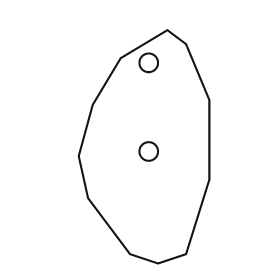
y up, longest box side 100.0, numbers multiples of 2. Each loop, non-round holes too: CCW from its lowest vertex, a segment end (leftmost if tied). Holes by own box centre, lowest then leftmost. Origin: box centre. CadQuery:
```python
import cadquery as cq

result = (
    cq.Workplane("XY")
    .moveTo(6.0, -50.0)
    .lineTo(18.0, -46.0)
    .lineTo(28.0, -14.0)
    .lineTo(28.0, 20.0)
    .lineTo(18.0, 44.0)
    .lineTo(10.0, 50.0)
    .lineTo(-10.0, 38.0)
    .lineTo(-22.0, 18.0)
    .lineTo(-28.0, -4.0)
    .lineTo(-24.0, -22.0)
    .lineTo(-6.0, -46.0)
    .close()
    .moveTo(2.0, -2.0)
    .circle(4.0)
    .moveTo(2.0, 36.0)
    .circle(4.0)
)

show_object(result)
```